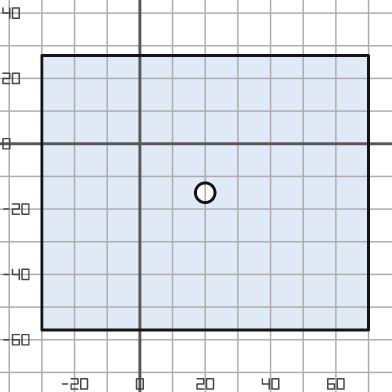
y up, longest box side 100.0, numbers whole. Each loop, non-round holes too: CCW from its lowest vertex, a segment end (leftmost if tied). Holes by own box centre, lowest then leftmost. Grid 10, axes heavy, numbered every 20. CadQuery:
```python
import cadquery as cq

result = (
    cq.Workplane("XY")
    .moveTo(-30.0, -57.0)
    .lineTo(70.0, -57.0)
    .lineTo(70.0, 27.0)
    .lineTo(-30.0, 27.0)
    .close()
    .moveTo(20.0, -15.0)
    .circle(3.0)
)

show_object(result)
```